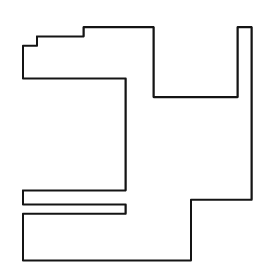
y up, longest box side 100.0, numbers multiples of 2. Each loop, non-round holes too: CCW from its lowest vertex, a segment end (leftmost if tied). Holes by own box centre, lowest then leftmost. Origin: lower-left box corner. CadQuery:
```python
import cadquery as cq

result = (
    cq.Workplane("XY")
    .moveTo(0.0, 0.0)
    .lineTo(72.0, 0.0)
    .lineTo(72.0, 26.0)
    .lineTo(98.0, 26.0)
    .lineTo(98.0, 100.0)
    .lineTo(92.0, 100.0)
    .lineTo(92.0, 70.0)
    .lineTo(56.0, 70.0)
    .lineTo(56.0, 100.0)
    .lineTo(26.0, 100.0)
    .lineTo(26.0, 96.0)
    .lineTo(6.0, 96.0)
    .lineTo(6.0, 92.0)
    .lineTo(0.0, 92.0)
    .lineTo(0.0, 78.0)
    .lineTo(44.0, 78.0)
    .lineTo(44.0, 30.0)
    .lineTo(0.0, 30.0)
    .lineTo(0.0, 24.0)
    .lineTo(44.0, 24.0)
    .lineTo(44.0, 20.0)
    .lineTo(0.0, 20.0)
    .close()
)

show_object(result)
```